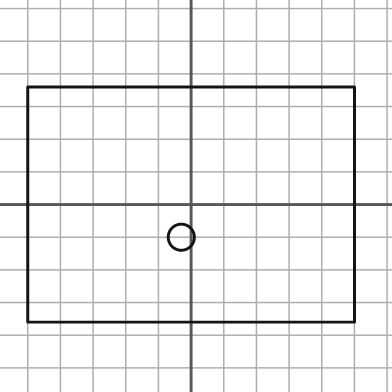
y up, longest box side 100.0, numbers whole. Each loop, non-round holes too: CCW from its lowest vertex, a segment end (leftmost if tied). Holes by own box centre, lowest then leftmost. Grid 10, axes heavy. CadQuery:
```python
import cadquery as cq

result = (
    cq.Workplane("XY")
    .moveTo(-50.0, -36.0)
    .lineTo(50.0, -36.0)
    .lineTo(50.0, 36.0)
    .lineTo(-50.0, 36.0)
    .close()
    .moveTo(-3.0, -10.0)
    .circle(4.0)
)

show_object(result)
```